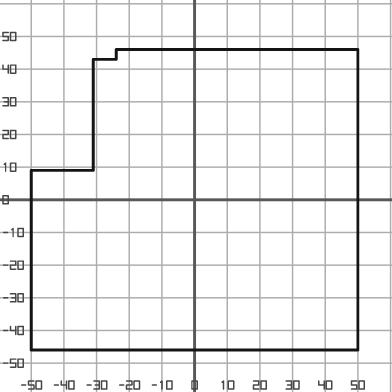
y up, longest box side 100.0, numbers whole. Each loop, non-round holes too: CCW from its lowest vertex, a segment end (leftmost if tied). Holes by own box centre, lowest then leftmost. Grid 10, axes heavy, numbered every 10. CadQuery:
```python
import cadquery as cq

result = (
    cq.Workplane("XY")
    .moveTo(-50.0, -46.0)
    .lineTo(50.0, -46.0)
    .lineTo(50.0, 46.0)
    .lineTo(-24.0, 46.0)
    .lineTo(-24.0, 43.0)
    .lineTo(-31.0, 43.0)
    .lineTo(-31.0, 9.0)
    .lineTo(-50.0, 9.0)
    .close()
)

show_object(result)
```